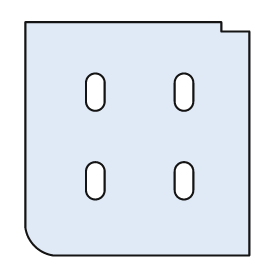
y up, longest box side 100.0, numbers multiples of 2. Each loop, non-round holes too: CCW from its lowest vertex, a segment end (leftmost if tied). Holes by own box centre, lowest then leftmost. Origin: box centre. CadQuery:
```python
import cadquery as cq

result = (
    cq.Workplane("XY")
    .moveTo(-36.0, -50.0)
    .lineTo(48.0, -50.0)
    .lineTo(48.0, 46.0)
    .lineTo(36.0, 46.0)
    .lineTo(36.0, 50.0)
    .lineTo(-48.0, 50.0)
    .lineTo(-48.0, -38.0)
    .threePointArc((-44.0, -46.0), (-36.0, -50.0))
    .close()
    .moveTo(-22.0, -22.0)
    .threePointArc((-18.0, -26.0), (-14.0, -22.0))
    .lineTo(-14.0, -14.0)
    .threePointArc((-18.0, -10.0), (-22.0, -14.0))
    .close()
    .moveTo(16.0, -22.0)
    .threePointArc((20.0, -26.0), (24.0, -22.0))
    .lineTo(24.0, -14.0)
    .threePointArc((20.0, -10.0), (16.0, -14.0))
    .close()
    .moveTo(-22.0, 16.0)
    .threePointArc((-18.0, 12.0), (-14.0, 16.0))
    .lineTo(-14.0, 24.0)
    .threePointArc((-18.0, 28.0), (-22.0, 24.0))
    .close()
    .moveTo(16.0, 16.0)
    .threePointArc((20.0, 12.0), (24.0, 16.0))
    .lineTo(24.0, 24.0)
    .threePointArc((20.0, 28.0), (16.0, 24.0))
    .close()
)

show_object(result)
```